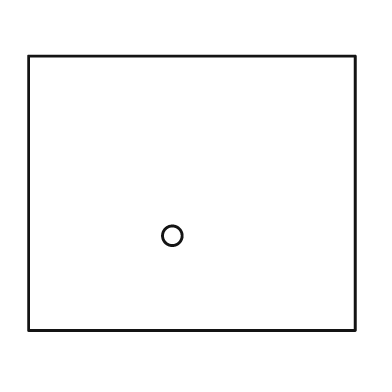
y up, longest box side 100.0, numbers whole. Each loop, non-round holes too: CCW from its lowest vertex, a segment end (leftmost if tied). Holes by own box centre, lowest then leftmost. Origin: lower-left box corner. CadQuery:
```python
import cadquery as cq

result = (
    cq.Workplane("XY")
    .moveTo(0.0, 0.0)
    .lineTo(100.0, 0.0)
    .lineTo(100.0, 84.0)
    .lineTo(0.0, 84.0)
    .close()
    .moveTo(44.0, 29.0)
    .circle(3.0)
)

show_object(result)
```